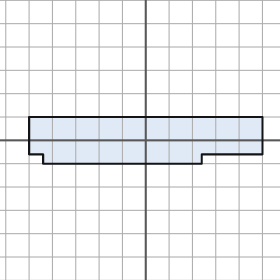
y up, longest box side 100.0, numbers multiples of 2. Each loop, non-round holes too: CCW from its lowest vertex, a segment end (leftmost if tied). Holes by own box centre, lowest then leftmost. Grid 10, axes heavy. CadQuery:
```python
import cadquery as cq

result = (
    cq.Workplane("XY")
    .moveTo(-44.0, -10.0)
    .lineTo(24.0, -10.0)
    .lineTo(24.0, -6.0)
    .lineTo(50.0, -6.0)
    .lineTo(50.0, 10.0)
    .lineTo(-50.0, 10.0)
    .lineTo(-50.0, -6.0)
    .lineTo(-44.0, -6.0)
    .close()
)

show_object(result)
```